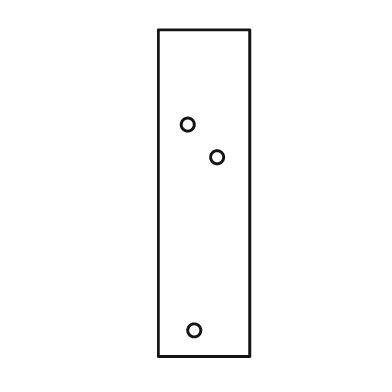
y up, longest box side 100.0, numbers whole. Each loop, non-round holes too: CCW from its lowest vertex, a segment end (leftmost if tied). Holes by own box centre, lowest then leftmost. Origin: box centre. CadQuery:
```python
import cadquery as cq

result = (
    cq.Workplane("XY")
    .moveTo(-14.0, -50.0)
    .lineTo(14.0, -50.0)
    .lineTo(14.0, 50.0)
    .lineTo(-14.0, 50.0)
    .close()
    .moveTo(-3.0, -42.0)
    .circle(2.0)
    .moveTo(4.0, 11.0)
    .circle(2.0)
    .moveTo(-5.0, 21.0)
    .circle(2.0)
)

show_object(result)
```